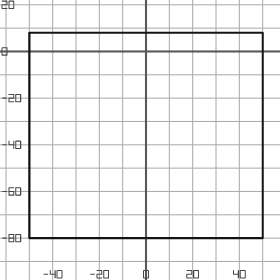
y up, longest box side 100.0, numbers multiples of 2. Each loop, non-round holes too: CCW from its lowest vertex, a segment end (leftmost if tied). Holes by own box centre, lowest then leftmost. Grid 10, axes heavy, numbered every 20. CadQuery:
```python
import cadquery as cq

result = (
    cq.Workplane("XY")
    .moveTo(-50.0, -80.0)
    .lineTo(50.0, -80.0)
    .lineTo(50.0, 8.0)
    .lineTo(-50.0, 8.0)
    .close()
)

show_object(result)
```